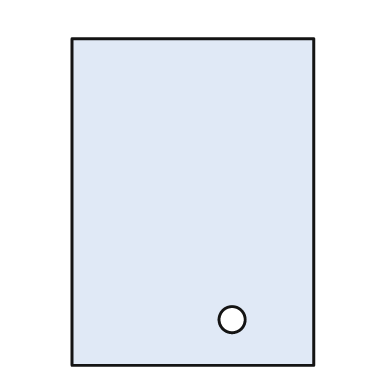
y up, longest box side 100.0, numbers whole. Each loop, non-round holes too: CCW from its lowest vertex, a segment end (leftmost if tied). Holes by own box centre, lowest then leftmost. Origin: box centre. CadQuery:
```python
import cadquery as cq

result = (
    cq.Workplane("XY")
    .moveTo(-37.0, -50.0)
    .lineTo(37.0, -50.0)
    .lineTo(37.0, 50.0)
    .lineTo(-37.0, 50.0)
    .close()
    .moveTo(12.0, -36.0)
    .circle(4.0)
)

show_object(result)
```